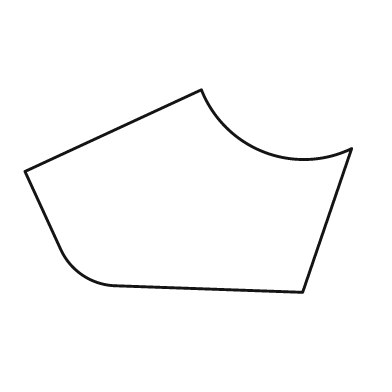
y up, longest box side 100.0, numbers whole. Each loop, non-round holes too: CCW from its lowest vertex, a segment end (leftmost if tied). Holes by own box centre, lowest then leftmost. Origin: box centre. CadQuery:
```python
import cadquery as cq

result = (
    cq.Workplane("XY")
    .moveTo(35.0, -31.0)
    .lineTo(50.0, 13.0)
    .threePointArc((23.0, 12.0), (4.0, 31.0))
    .lineTo(-50.0, 6.0)
    .lineTo(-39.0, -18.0)
    .threePointArc((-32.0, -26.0), (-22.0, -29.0))
    .close()
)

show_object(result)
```